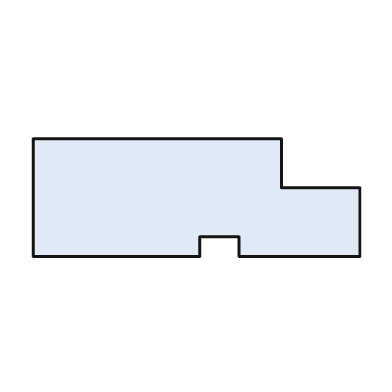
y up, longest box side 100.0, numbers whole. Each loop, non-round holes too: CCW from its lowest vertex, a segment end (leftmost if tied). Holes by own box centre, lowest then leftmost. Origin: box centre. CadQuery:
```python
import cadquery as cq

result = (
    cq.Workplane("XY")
    .moveTo(-50.0, -18.0)
    .lineTo(1.0, -18.0)
    .lineTo(1.0, -12.0)
    .lineTo(13.0, -12.0)
    .lineTo(13.0, -18.0)
    .lineTo(50.0, -18.0)
    .lineTo(50.0, 3.0)
    .lineTo(26.0, 3.0)
    .lineTo(26.0, 18.0)
    .lineTo(-50.0, 18.0)
    .close()
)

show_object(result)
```